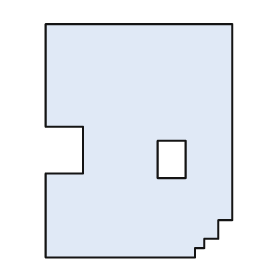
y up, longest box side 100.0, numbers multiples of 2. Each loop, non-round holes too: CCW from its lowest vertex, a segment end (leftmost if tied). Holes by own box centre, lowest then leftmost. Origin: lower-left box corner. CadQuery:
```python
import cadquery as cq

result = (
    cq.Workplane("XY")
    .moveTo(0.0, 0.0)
    .lineTo(64.0, 0.0)
    .lineTo(64.0, 4.0)
    .lineTo(68.0, 4.0)
    .lineTo(68.0, 8.0)
    .lineTo(74.0, 8.0)
    .lineTo(74.0, 16.0)
    .lineTo(80.0, 16.0)
    .lineTo(80.0, 100.0)
    .lineTo(0.0, 100.0)
    .lineTo(0.0, 56.0)
    .lineTo(16.0, 56.0)
    .lineTo(16.0, 36.0)
    .lineTo(0.0, 36.0)
    .close()
    .moveTo(48.0, 34.0)
    .lineTo(60.0, 34.0)
    .lineTo(60.0, 50.0)
    .lineTo(48.0, 50.0)
    .close()
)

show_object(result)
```